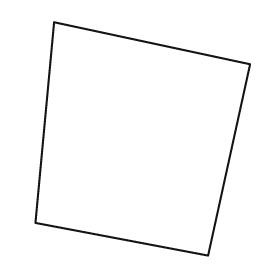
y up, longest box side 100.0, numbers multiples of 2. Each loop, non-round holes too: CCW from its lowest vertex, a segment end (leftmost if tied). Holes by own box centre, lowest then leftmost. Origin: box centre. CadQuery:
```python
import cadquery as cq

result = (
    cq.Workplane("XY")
    .moveTo(28.0, -50.0)
    .lineTo(46.0, 32.0)
    .lineTo(-38.0, 50.0)
    .lineTo(-46.0, -36.0)
    .close()
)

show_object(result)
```